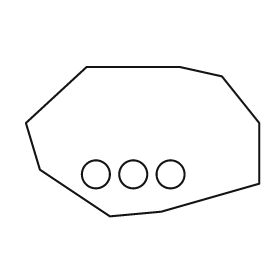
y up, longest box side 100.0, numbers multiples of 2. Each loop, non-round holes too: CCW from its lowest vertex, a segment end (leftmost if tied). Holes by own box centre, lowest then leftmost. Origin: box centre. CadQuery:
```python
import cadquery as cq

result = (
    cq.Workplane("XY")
    .moveTo(-14.0, -32.0)
    .lineTo(8.0, -30.0)
    .lineTo(50.0, -18.0)
    .lineTo(50.0, 8.0)
    .lineTo(34.0, 28.0)
    .lineTo(16.0, 32.0)
    .lineTo(-24.0, 32.0)
    .lineTo(-50.0, 8.0)
    .lineTo(-44.0, -12.0)
    .close()
    .moveTo(-20.0, -14.0)
    .circle(6.0)
    .moveTo(-4.0, -14.0)
    .circle(6.0)
    .moveTo(12.0, -14.0)
    .circle(6.0)
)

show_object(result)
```